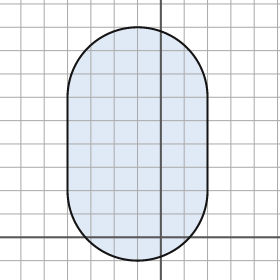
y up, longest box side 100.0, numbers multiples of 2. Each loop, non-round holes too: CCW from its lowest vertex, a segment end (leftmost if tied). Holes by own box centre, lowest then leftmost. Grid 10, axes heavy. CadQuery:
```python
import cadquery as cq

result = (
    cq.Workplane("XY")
    .moveTo(-40.0, 20.0)
    .threePointArc((-10.0, -10.0), (20.0, 20.0))
    .lineTo(20.0, 60.0)
    .threePointArc((-10.0, 90.0), (-40.0, 60.0))
    .close()
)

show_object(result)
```